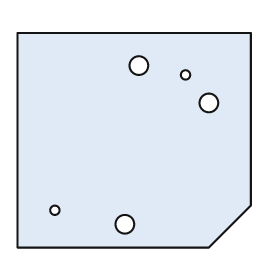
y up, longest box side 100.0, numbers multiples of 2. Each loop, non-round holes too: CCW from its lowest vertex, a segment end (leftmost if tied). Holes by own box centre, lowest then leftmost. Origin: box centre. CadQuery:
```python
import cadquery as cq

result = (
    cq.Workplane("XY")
    .moveTo(-50.0, -46.0)
    .lineTo(32.0, -46.0)
    .lineTo(50.0, -28.0)
    .lineTo(50.0, 46.0)
    .lineTo(-50.0, 46.0)
    .close()
    .moveTo(-4.0, -36.0)
    .circle(4.0)
    .moveTo(-34.0, -30.0)
    .circle(2.0)
    .moveTo(32.0, 16.0)
    .circle(4.0)
    .moveTo(22.0, 28.0)
    .circle(2.0)
    .moveTo(2.0, 32.0)
    .circle(4.0)
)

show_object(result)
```